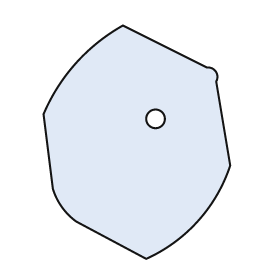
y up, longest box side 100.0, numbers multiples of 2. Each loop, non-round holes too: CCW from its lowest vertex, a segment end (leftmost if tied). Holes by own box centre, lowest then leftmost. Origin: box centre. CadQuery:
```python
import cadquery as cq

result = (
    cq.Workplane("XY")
    .moveTo(4.0, -50.0)
    .threePointArc((26.0, -34.0), (40.0, -10.0))
    .lineTo(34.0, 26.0)
    .threePointArc((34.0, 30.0), (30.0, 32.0))
    .lineTo(-6.0, 50.0)
    .threePointArc((-26.0, 34.0), (-40.0, 12.0))
    .lineTo(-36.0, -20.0)
    .threePointArc((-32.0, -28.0), (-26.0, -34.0))
    .close()
    .moveTo(8.0, 10.0)
    .circle(4.0)
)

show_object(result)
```